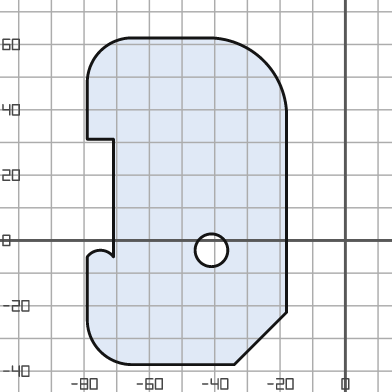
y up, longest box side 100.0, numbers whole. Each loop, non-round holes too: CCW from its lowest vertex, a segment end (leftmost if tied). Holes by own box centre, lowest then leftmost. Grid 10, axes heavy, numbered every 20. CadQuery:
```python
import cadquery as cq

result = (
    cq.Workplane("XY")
    .moveTo(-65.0, -38.0)
    .lineTo(-34.0, -38.0)
    .lineTo(-18.0, -22.0)
    .lineTo(-18.0, 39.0)
    .threePointArc((-25.0, 55.0), (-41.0, 62.0))
    .lineTo(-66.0, 62.0)
    .threePointArc((-75.0, 58.0), (-79.0, 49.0))
    .lineTo(-79.0, 31.0)
    .lineTo(-71.0, 31.0)
    .lineTo(-71.0, -5.0)
    .threePointArc((-75.0, -3.0), (-79.0, -5.0))
    .lineTo(-79.0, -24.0)
    .threePointArc((-75.0, -34.0), (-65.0, -38.0))
    .close()
    .moveTo(-41.0, -3.0)
    .circle(5.0)
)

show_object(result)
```